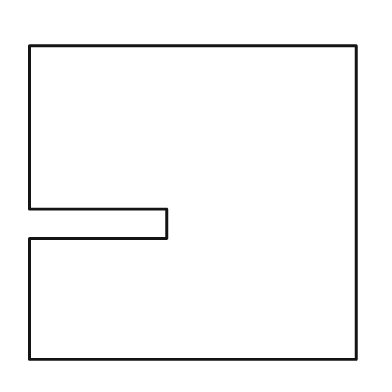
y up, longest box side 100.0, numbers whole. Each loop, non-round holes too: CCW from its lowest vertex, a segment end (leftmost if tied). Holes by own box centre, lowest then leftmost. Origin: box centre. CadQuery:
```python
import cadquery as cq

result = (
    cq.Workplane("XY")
    .moveTo(-50.0, -48.0)
    .lineTo(50.0, -48.0)
    .lineTo(50.0, 48.0)
    .lineTo(-50.0, 48.0)
    .lineTo(-50.0, -2.0)
    .lineTo(-8.0, -2.0)
    .lineTo(-8.0, -11.0)
    .lineTo(-50.0, -11.0)
    .close()
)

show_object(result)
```